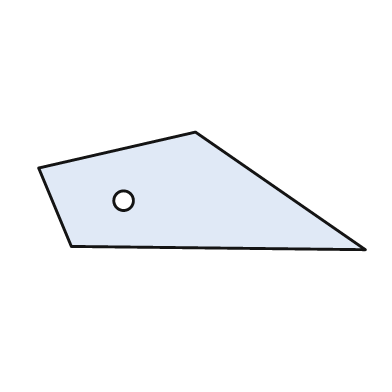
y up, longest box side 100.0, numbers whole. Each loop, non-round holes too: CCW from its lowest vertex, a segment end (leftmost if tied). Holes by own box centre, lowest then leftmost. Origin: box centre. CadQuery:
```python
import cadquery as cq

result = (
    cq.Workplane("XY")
    .moveTo(50.0, -18.0)
    .lineTo(-2.0, 18.0)
    .lineTo(-50.0, 7.0)
    .lineTo(-40.0, -17.0)
    .close()
    .moveTo(-24.0, -3.0)
    .circle(3.0)
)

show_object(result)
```